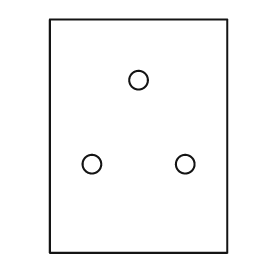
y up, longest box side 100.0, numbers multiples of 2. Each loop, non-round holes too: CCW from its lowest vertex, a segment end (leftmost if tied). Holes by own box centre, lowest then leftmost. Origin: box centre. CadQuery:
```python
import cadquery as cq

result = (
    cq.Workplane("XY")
    .moveTo(-38.0, -50.0)
    .lineTo(38.0, -50.0)
    .lineTo(38.0, 50.0)
    .lineTo(-38.0, 50.0)
    .close()
    .moveTo(-20.0, -12.0)
    .circle(4.0)
    .moveTo(20.0, -12.0)
    .circle(4.0)
    .moveTo(0.0, 24.0)
    .circle(4.0)
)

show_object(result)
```